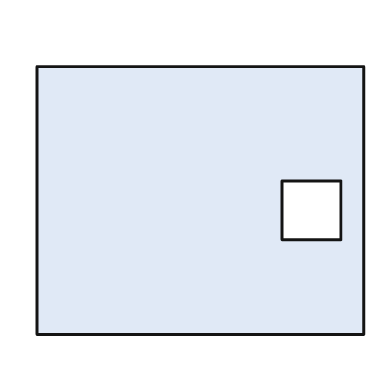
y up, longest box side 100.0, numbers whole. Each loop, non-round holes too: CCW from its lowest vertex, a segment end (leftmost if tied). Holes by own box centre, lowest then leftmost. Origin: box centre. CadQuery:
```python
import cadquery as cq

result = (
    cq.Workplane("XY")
    .moveTo(-50.0, -41.0)
    .lineTo(50.0, -41.0)
    .lineTo(50.0, 41.0)
    .lineTo(-50.0, 41.0)
    .close()
    .moveTo(25.0, -12.0)
    .lineTo(43.0, -12.0)
    .lineTo(43.0, 6.0)
    .lineTo(25.0, 6.0)
    .close()
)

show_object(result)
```